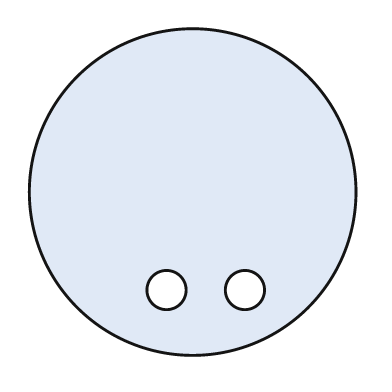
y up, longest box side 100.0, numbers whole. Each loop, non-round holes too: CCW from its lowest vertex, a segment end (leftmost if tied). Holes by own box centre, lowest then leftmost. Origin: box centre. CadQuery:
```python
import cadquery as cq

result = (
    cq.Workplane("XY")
    .moveTo(0.0, 0.0)
    .circle(50.0)
    .moveTo(-8.0, -30.0)
    .circle(6.0)
    .moveTo(16.0, -30.0)
    .circle(6.0)
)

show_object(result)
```